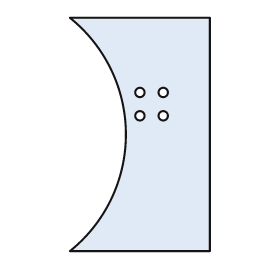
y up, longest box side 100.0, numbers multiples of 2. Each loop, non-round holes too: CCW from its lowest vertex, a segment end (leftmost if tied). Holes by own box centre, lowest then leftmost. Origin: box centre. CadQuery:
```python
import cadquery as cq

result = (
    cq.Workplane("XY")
    .moveTo(-30.0, -50.0)
    .lineTo(30.0, -50.0)
    .lineTo(30.0, 50.0)
    .lineTo(-30.0, 50.0)
    .threePointArc((-6.0, 0.0), (-30.0, -50.0))
    .close()
    .moveTo(0.0, 8.0)
    .circle(2.0)
    .moveTo(10.0, 8.0)
    .circle(2.0)
    .moveTo(0.0, 18.0)
    .circle(2.0)
    .moveTo(10.0, 18.0)
    .circle(2.0)
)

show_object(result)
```